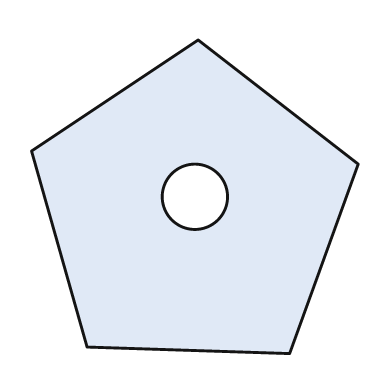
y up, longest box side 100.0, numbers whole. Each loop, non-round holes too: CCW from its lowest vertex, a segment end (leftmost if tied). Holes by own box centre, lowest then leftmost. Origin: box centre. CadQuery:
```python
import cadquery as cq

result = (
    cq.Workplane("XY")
    .moveTo(29.0, -48.0)
    .lineTo(50.0, 10.0)
    .lineTo(1.0, 48.0)
    .lineTo(-50.0, 14.0)
    .lineTo(-33.0, -46.0)
    .close()
    .moveTo(0.0, 0.0)
    .circle(10.0)
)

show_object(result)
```